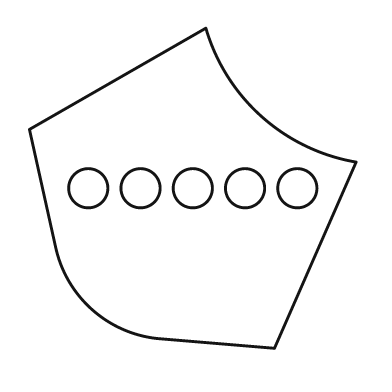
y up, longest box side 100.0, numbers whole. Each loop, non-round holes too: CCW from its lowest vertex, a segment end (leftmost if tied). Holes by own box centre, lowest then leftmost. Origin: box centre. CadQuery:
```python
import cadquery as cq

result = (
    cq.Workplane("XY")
    .moveTo(25.0, -49.0)
    .lineTo(50.0, 8.0)
    .threePointArc((21.0, 22.0), (4.0, 49.0))
    .lineTo(-50.0, 18.0)
    .lineTo(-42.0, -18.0)
    .threePointArc((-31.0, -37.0), (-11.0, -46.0))
    .close()
    .moveTo(-32.0, 0.0)
    .circle(6.0)
    .moveTo(-16.0, 0.0)
    .circle(6.0)
    .moveTo(0.0, 0.0)
    .circle(6.0)
    .moveTo(16.0, 0.0)
    .circle(6.0)
    .moveTo(32.0, 0.0)
    .circle(6.0)
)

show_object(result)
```